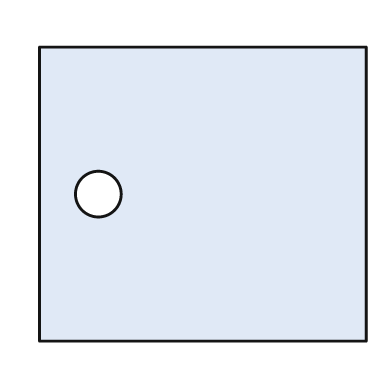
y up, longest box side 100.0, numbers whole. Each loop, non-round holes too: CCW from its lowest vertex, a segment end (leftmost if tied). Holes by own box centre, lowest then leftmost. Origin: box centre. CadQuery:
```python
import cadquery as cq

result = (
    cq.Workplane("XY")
    .moveTo(-50.0, -45.0)
    .lineTo(50.0, -45.0)
    .lineTo(50.0, 45.0)
    .lineTo(-50.0, 45.0)
    .close()
    .moveTo(-32.0, 0.0)
    .circle(7.0)
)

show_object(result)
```